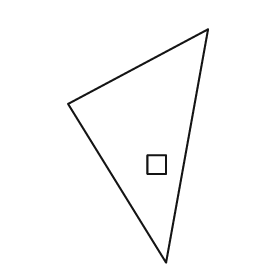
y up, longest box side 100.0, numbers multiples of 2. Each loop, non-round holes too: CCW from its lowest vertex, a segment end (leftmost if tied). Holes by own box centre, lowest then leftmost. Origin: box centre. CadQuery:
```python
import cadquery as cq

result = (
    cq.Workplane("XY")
    .moveTo(12.0, -50.0)
    .lineTo(30.0, 50.0)
    .lineTo(-30.0, 18.0)
    .close()
    .moveTo(4.0, -12.0)
    .lineTo(12.0, -12.0)
    .lineTo(12.0, -4.0)
    .lineTo(4.0, -4.0)
    .close()
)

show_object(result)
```